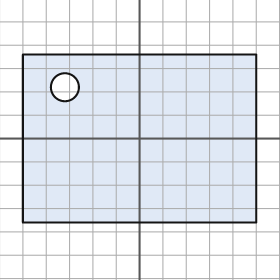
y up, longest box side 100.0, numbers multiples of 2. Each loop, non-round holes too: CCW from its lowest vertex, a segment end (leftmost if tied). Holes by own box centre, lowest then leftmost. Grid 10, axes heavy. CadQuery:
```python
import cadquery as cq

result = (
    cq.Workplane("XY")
    .moveTo(-50.0, -36.0)
    .lineTo(50.0, -36.0)
    .lineTo(50.0, 36.0)
    .lineTo(-50.0, 36.0)
    .close()
    .moveTo(-32.0, 22.0)
    .circle(6.0)
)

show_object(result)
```